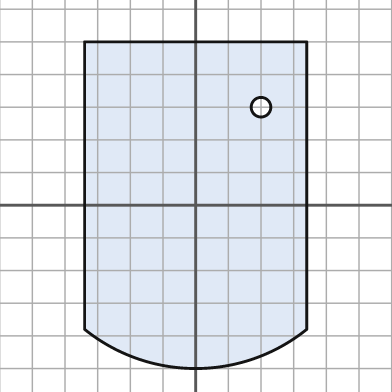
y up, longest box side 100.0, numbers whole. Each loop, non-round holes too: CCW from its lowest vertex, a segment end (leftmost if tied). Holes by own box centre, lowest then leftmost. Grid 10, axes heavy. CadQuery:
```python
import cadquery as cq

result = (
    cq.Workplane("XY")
    .moveTo(-34.0, -38.0)
    .threePointArc((0.0, -50.0), (34.0, -38.0))
    .lineTo(34.0, 50.0)
    .lineTo(-34.0, 50.0)
    .close()
    .moveTo(20.0, 30.0)
    .circle(3.0)
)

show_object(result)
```